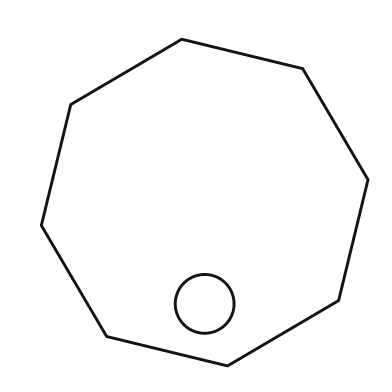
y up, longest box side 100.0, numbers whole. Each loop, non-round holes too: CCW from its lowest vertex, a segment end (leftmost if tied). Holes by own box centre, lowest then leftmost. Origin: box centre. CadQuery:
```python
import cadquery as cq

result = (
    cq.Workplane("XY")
    .moveTo(7.0, -50.0)
    .lineTo(41.0, -30.0)
    .lineTo(50.0, 7.0)
    .lineTo(30.0, 41.0)
    .lineTo(-7.0, 50.0)
    .lineTo(-41.0, 30.0)
    .lineTo(-50.0, -7.0)
    .lineTo(-30.0, -41.0)
    .close()
    .moveTo(0.0, -31.0)
    .circle(9.0)
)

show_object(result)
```